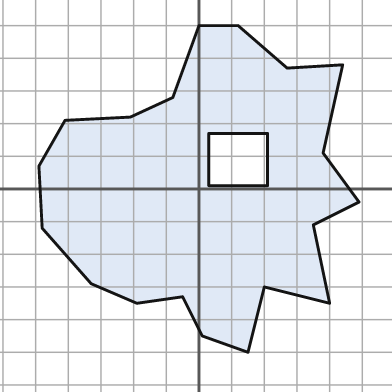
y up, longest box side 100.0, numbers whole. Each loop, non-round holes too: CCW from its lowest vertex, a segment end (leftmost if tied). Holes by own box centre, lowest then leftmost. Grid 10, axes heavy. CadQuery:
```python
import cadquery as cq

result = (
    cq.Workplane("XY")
    .moveTo(15.0, -50.0)
    .lineTo(20.0, -30.0)
    .lineTo(40.0, -35.0)
    .lineTo(35.0, -11.0)
    .lineTo(49.0, -4.0)
    .lineTo(38.0, 11.0)
    .lineTo(44.0, 38.0)
    .lineTo(27.0, 37.0)
    .lineTo(12.0, 50.0)
    .lineTo(0.0, 50.0)
    .lineTo(-8.0, 28.0)
    .lineTo(-21.0, 22.0)
    .lineTo(-41.0, 21.0)
    .lineTo(-49.0, 7.0)
    .lineTo(-48.0, -12.0)
    .lineTo(-33.0, -29.0)
    .lineTo(-19.0, -35.0)
    .lineTo(-5.0, -33.0)
    .lineTo(1.0, -45.0)
    .close()
    .moveTo(3.0, 1.0)
    .lineTo(21.0, 1.0)
    .lineTo(21.0, 17.0)
    .lineTo(3.0, 17.0)
    .close()
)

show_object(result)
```